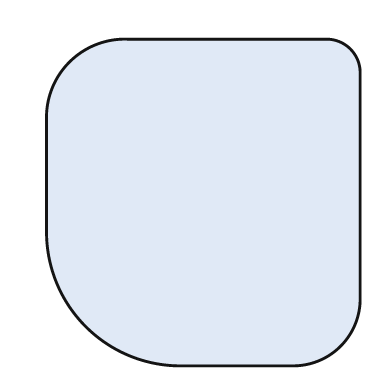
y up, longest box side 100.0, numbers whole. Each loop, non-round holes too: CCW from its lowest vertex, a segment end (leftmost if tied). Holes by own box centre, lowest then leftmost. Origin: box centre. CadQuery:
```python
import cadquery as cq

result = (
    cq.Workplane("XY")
    .moveTo(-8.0, -50.0)
    .lineTo(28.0, -50.0)
    .threePointArc((42.0, -44.0), (48.0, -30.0))
    .lineTo(48.0, 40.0)
    .threePointArc((45.0, 47.0), (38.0, 50.0))
    .lineTo(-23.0, 50.0)
    .threePointArc((-41.0, 43.0), (-48.0, 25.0))
    .lineTo(-48.0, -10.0)
    .threePointArc((-36.0, -38.0), (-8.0, -50.0))
    .close()
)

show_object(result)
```